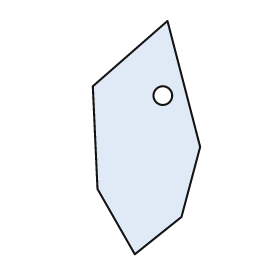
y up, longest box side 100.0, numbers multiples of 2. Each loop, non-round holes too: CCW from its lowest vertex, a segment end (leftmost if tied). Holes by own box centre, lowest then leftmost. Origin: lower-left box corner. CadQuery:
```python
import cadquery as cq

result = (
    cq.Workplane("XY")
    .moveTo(18.0, 0.0)
    .lineTo(38.0, 16.0)
    .lineTo(46.0, 46.0)
    .lineTo(32.0, 100.0)
    .lineTo(0.0, 72.0)
    .lineTo(2.0, 28.0)
    .close()
    .moveTo(30.0, 68.0)
    .circle(4.0)
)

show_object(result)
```